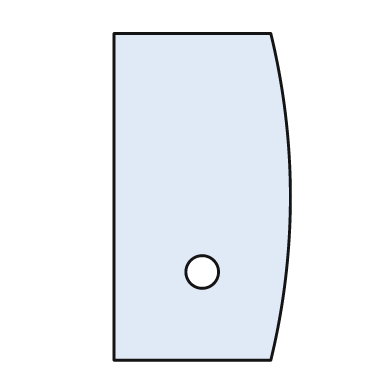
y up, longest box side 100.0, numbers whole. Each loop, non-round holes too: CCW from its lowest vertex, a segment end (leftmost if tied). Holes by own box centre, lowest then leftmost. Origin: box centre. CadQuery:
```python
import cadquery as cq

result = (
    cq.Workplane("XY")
    .moveTo(-27.0, -50.0)
    .lineTo(21.0, -50.0)
    .threePointArc((27.0, 0.0), (21.0, 50.0))
    .lineTo(-27.0, 50.0)
    .close()
    .moveTo(0.0, -23.0)
    .circle(5.0)
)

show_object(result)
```